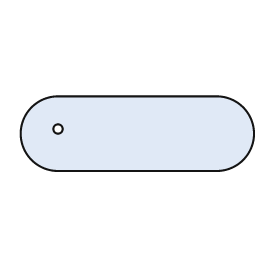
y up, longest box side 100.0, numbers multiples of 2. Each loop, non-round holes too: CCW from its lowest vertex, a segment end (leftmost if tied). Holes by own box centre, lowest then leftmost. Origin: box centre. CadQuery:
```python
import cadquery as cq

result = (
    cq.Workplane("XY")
    .moveTo(-34.0, -16.0)
    .lineTo(34.0, -16.0)
    .threePointArc((50.0, 0.0), (34.0, 16.0))
    .lineTo(-34.0, 16.0)
    .threePointArc((-50.0, 0.0), (-34.0, -16.0))
    .close()
    .moveTo(-34.0, 2.0)
    .circle(2.0)
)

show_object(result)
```